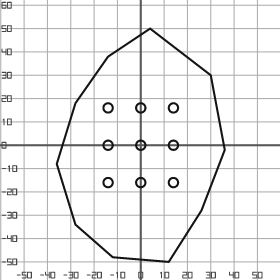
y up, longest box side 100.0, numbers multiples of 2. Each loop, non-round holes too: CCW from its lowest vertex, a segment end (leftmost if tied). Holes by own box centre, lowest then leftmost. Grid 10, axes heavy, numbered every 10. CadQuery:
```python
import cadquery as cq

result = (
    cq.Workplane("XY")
    .moveTo(12.0, -50.0)
    .lineTo(26.0, -28.0)
    .lineTo(36.0, -2.0)
    .lineTo(30.0, 30.0)
    .lineTo(4.0, 50.0)
    .lineTo(-14.0, 38.0)
    .lineTo(-28.0, 18.0)
    .lineTo(-36.0, -8.0)
    .lineTo(-28.0, -34.0)
    .lineTo(-12.0, -48.0)
    .close()
    .moveTo(-14.0, -16.0)
    .circle(2.0)
    .moveTo(0.0, -16.0)
    .circle(2.0)
    .moveTo(14.0, -16.0)
    .circle(2.0)
    .moveTo(-14.0, 0.0)
    .circle(2.0)
    .moveTo(0.0, 0.0)
    .circle(2.0)
    .moveTo(14.0, 0.0)
    .circle(2.0)
    .moveTo(-14.0, 16.0)
    .circle(2.0)
    .moveTo(0.0, 16.0)
    .circle(2.0)
    .moveTo(14.0, 16.0)
    .circle(2.0)
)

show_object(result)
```